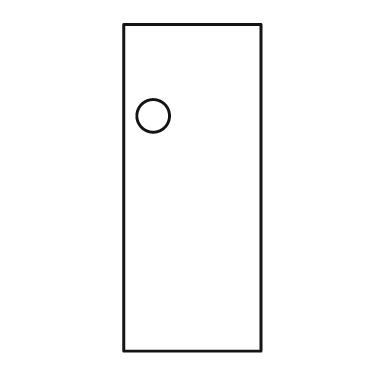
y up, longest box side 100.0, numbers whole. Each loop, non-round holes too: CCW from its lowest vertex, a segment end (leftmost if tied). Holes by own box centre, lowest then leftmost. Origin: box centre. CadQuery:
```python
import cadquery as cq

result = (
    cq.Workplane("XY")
    .moveTo(-21.0, -50.0)
    .lineTo(21.0, -50.0)
    .lineTo(21.0, 50.0)
    .lineTo(-21.0, 50.0)
    .close()
    .moveTo(-12.0, 22.0)
    .circle(5.0)
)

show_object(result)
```